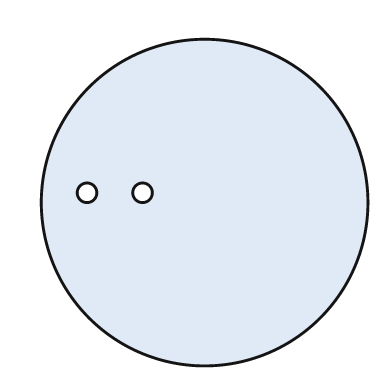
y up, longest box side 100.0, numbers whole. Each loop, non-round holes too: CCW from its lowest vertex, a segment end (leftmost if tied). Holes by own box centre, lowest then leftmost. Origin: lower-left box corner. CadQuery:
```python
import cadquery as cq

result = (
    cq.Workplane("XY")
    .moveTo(50.0, 50.0)
    .circle(50.0)
    .moveTo(14.0, 53.0)
    .circle(3.0)
    .moveTo(31.0, 53.0)
    .circle(3.0)
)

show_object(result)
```